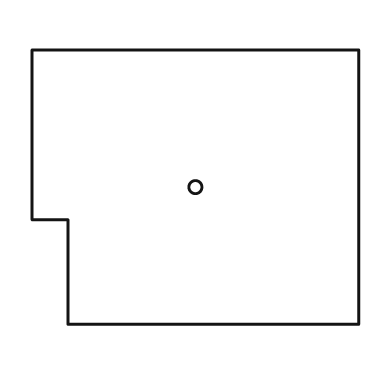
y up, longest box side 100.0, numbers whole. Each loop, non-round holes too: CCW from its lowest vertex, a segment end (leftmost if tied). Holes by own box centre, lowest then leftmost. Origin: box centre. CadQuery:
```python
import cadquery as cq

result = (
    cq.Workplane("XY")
    .moveTo(-39.0, -42.0)
    .lineTo(50.0, -42.0)
    .lineTo(50.0, 42.0)
    .lineTo(-50.0, 42.0)
    .lineTo(-50.0, -10.0)
    .lineTo(-39.0, -10.0)
    .close()
    .moveTo(0.0, 0.0)
    .circle(2.0)
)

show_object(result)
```